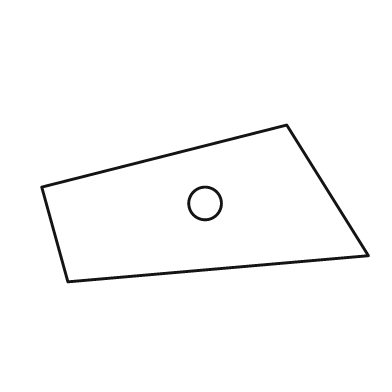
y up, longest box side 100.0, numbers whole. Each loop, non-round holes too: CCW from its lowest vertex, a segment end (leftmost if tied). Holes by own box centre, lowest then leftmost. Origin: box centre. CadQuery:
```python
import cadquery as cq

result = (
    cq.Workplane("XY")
    .moveTo(-42.0, -24.0)
    .lineTo(50.0, -16.0)
    .lineTo(25.0, 24.0)
    .lineTo(-50.0, 5.0)
    .close()
    .moveTo(0.0, 0.0)
    .circle(5.0)
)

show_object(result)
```